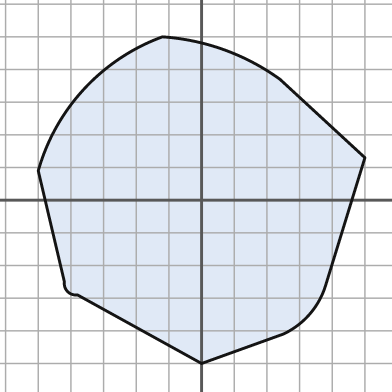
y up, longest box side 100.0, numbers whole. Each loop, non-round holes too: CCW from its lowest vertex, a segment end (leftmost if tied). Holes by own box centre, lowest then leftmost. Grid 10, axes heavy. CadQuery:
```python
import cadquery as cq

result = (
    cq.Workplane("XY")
    .moveTo(0.0, -50.0)
    .lineTo(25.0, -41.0)
    .threePointArc((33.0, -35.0), (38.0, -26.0))
    .lineTo(50.0, 13.0)
    .lineTo(24.0, 37.0)
    .threePointArc((7.0, 46.0), (-12.0, 50.0))
    .threePointArc((-36.0, 34.0), (-50.0, 9.0))
    .lineTo(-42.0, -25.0)
    .threePointArc((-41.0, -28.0), (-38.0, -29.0))
    .close()
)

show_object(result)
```